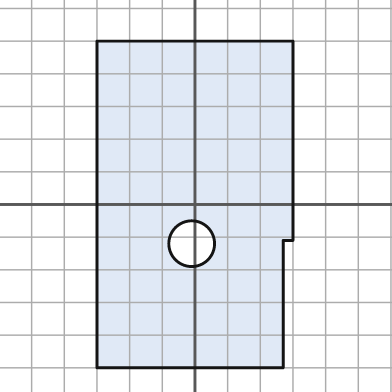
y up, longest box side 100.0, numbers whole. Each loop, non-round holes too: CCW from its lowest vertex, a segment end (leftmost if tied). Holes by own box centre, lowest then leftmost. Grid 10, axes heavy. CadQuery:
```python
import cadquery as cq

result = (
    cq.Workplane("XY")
    .moveTo(-30.0, -50.0)
    .lineTo(27.0, -50.0)
    .lineTo(27.0, -11.0)
    .lineTo(30.0, -11.0)
    .lineTo(30.0, 50.0)
    .lineTo(-30.0, 50.0)
    .close()
    .moveTo(-1.0, -12.0)
    .circle(7.0)
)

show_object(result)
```